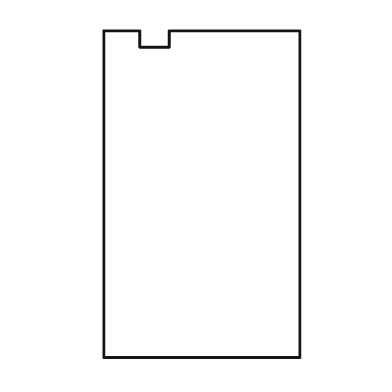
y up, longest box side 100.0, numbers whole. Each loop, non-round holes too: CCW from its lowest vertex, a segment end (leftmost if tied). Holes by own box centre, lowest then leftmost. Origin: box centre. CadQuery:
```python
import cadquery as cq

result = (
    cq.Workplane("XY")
    .moveTo(-30.0, -50.0)
    .lineTo(30.0, -50.0)
    .lineTo(30.0, 50.0)
    .lineTo(-10.0, 50.0)
    .lineTo(-10.0, 45.0)
    .lineTo(-19.0, 45.0)
    .lineTo(-19.0, 50.0)
    .lineTo(-30.0, 50.0)
    .close()
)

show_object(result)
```